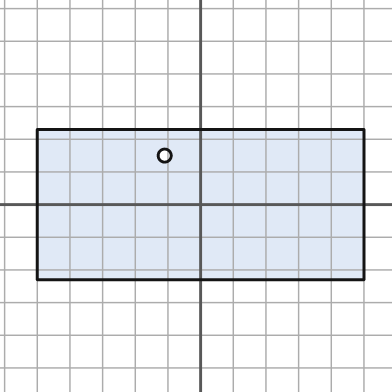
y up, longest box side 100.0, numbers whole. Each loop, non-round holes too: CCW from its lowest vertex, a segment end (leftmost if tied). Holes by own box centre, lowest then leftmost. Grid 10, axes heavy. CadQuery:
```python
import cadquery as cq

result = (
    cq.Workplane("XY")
    .moveTo(-50.0, -23.0)
    .lineTo(50.0, -23.0)
    .lineTo(50.0, 23.0)
    .lineTo(-50.0, 23.0)
    .close()
    .moveTo(-11.0, 15.0)
    .circle(2.0)
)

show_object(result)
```